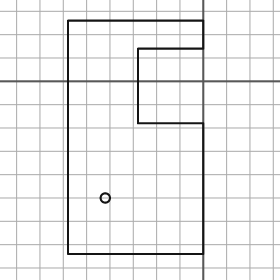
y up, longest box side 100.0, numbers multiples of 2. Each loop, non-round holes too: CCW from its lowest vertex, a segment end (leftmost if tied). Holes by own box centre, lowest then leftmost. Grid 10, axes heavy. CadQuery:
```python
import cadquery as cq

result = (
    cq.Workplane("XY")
    .moveTo(-58.0, -74.0)
    .lineTo(0.0, -74.0)
    .lineTo(0.0, -18.0)
    .lineTo(-28.0, -18.0)
    .lineTo(-28.0, 14.0)
    .lineTo(0.0, 14.0)
    .lineTo(0.0, 26.0)
    .lineTo(-58.0, 26.0)
    .close()
    .moveTo(-42.0, -50.0)
    .circle(2.0)
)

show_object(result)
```